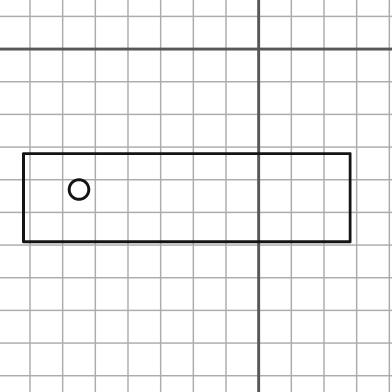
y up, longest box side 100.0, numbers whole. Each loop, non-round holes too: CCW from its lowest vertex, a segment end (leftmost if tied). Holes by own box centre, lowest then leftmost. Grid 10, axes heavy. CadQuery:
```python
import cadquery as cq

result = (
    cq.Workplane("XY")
    .moveTo(-72.0, -59.0)
    .lineTo(28.0, -59.0)
    .lineTo(28.0, -32.0)
    .lineTo(-72.0, -32.0)
    .close()
    .moveTo(-55.0, -43.0)
    .circle(3.0)
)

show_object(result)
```